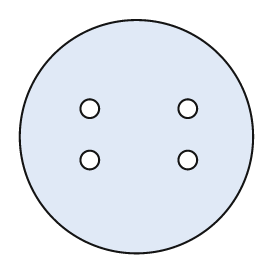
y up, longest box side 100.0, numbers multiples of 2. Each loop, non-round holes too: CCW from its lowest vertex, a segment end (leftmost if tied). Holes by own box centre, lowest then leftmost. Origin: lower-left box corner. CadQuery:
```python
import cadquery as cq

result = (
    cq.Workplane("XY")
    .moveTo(50.0, 50.0)
    .circle(50.0)
    .moveTo(30.0, 40.0)
    .circle(4.0)
    .moveTo(72.0, 40.0)
    .circle(4.0)
    .moveTo(30.0, 62.0)
    .circle(4.0)
    .moveTo(72.0, 62.0)
    .circle(4.0)
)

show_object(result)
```